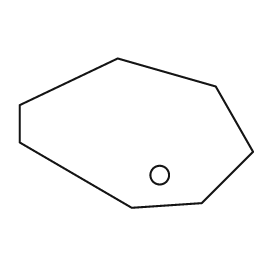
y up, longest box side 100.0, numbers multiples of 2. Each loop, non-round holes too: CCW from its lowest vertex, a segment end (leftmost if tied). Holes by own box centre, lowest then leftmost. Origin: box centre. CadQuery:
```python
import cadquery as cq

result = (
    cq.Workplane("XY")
    .moveTo(-2.0, -32.0)
    .lineTo(28.0, -30.0)
    .lineTo(50.0, -8.0)
    .lineTo(34.0, 20.0)
    .lineTo(-8.0, 32.0)
    .lineTo(-50.0, 12.0)
    .lineTo(-50.0, -4.0)
    .close()
    .moveTo(10.0, -18.0)
    .circle(4.0)
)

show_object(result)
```